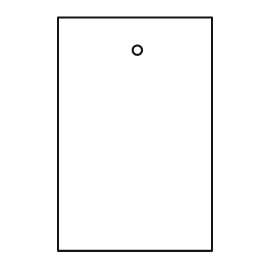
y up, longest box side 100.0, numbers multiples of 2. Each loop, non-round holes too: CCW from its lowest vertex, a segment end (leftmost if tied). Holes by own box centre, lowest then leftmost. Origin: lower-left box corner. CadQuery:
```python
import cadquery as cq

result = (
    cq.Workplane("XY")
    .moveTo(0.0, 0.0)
    .lineTo(66.0, 0.0)
    .lineTo(66.0, 100.0)
    .lineTo(0.0, 100.0)
    .close()
    .moveTo(34.0, 86.0)
    .circle(2.0)
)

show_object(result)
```